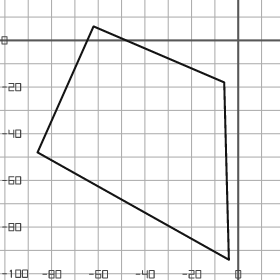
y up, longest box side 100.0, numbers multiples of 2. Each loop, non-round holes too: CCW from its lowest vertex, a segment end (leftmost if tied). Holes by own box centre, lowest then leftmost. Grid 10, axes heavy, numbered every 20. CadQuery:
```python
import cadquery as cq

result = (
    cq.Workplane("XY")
    .moveTo(-4.0, -94.0)
    .lineTo(-6.0, -18.0)
    .lineTo(-62.0, 6.0)
    .lineTo(-86.0, -48.0)
    .close()
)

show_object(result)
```